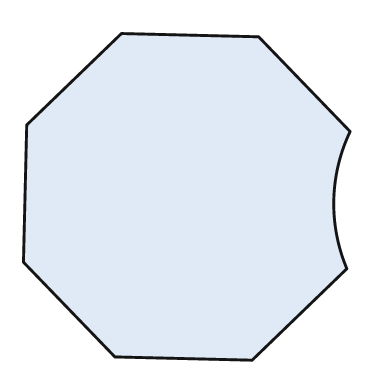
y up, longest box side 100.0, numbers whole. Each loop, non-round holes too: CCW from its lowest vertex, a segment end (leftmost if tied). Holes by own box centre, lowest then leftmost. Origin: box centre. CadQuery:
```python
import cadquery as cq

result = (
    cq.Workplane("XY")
    .moveTo(20.0, -50.0)
    .lineTo(49.0, -22.0)
    .threePointArc((45.0, -1.0), (50.0, 20.0))
    .lineTo(22.0, 49.0)
    .lineTo(-20.0, 50.0)
    .lineTo(-49.0, 22.0)
    .lineTo(-50.0, -20.0)
    .lineTo(-22.0, -49.0)
    .close()
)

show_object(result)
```